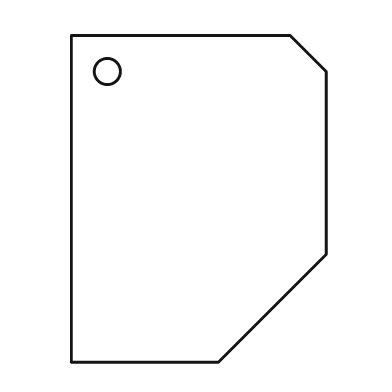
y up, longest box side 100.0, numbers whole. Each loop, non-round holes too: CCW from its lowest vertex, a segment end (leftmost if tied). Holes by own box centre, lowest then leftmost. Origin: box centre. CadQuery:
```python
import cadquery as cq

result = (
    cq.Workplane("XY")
    .moveTo(-39.0, -50.0)
    .lineTo(6.0, -50.0)
    .lineTo(39.0, -17.0)
    .lineTo(39.0, 39.0)
    .lineTo(28.0, 50.0)
    .lineTo(-39.0, 50.0)
    .close()
    .moveTo(-28.0, 39.0)
    .circle(4.0)
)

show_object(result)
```